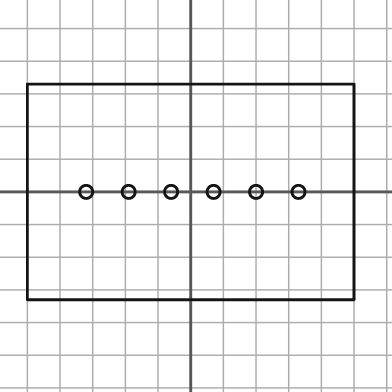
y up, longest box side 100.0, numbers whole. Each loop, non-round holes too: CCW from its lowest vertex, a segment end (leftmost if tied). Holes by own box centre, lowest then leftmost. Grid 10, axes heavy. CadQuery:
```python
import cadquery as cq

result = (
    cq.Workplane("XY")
    .moveTo(-50.0, -33.0)
    .lineTo(50.0, -33.0)
    .lineTo(50.0, 33.0)
    .lineTo(-50.0, 33.0)
    .close()
    .moveTo(-32.0, 0.0)
    .circle(2.0)
    .moveTo(-19.0, 0.0)
    .circle(2.0)
    .moveTo(-6.0, 0.0)
    .circle(2.0)
    .moveTo(7.0, 0.0)
    .circle(2.0)
    .moveTo(20.0, 0.0)
    .circle(2.0)
    .moveTo(33.0, 0.0)
    .circle(2.0)
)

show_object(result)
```